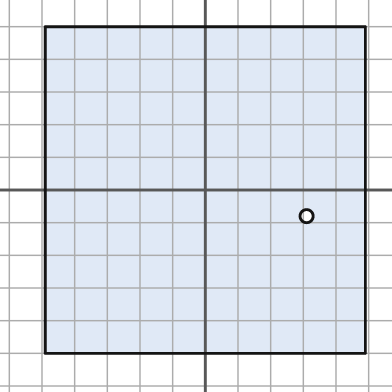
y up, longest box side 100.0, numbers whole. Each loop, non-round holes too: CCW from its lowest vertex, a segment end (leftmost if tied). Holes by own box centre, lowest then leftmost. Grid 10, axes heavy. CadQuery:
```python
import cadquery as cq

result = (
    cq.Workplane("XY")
    .moveTo(-49.0, -50.0)
    .lineTo(49.0, -50.0)
    .lineTo(49.0, 50.0)
    .lineTo(-49.0, 50.0)
    .close()
    .moveTo(31.0, -8.0)
    .circle(2.0)
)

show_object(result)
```